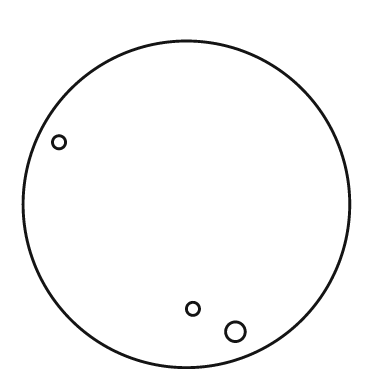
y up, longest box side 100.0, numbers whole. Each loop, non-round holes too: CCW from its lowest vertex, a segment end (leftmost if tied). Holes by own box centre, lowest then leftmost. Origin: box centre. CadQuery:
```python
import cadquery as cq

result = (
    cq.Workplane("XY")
    .moveTo(0.0, 0.0)
    .circle(50.0)
    .moveTo(15.0, -39.0)
    .circle(3.0)
    .moveTo(2.0, -32.0)
    .circle(2.0)
    .moveTo(-39.0, 19.0)
    .circle(2.0)
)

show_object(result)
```